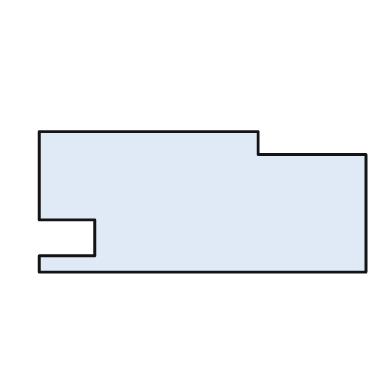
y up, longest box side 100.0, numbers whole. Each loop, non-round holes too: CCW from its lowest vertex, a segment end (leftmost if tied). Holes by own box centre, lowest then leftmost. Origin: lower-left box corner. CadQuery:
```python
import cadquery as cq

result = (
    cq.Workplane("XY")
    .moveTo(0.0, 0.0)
    .lineTo(100.0, 0.0)
    .lineTo(100.0, 36.0)
    .lineTo(67.0, 36.0)
    .lineTo(67.0, 43.0)
    .lineTo(0.0, 43.0)
    .lineTo(0.0, 16.0)
    .lineTo(17.0, 16.0)
    .lineTo(17.0, 5.0)
    .lineTo(0.0, 5.0)
    .close()
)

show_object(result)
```